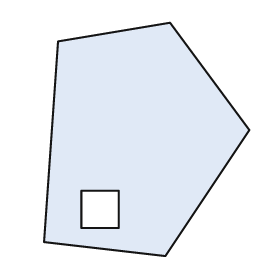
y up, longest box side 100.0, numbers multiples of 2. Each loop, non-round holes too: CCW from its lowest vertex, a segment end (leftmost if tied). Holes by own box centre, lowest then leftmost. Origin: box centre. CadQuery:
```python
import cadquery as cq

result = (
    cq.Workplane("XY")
    .moveTo(8.0, -50.0)
    .lineTo(44.0, 4.0)
    .lineTo(10.0, 50.0)
    .lineTo(-38.0, 42.0)
    .lineTo(-44.0, -44.0)
    .close()
    .moveTo(-28.0, -38.0)
    .lineTo(-12.0, -38.0)
    .lineTo(-12.0, -22.0)
    .lineTo(-28.0, -22.0)
    .close()
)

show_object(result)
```